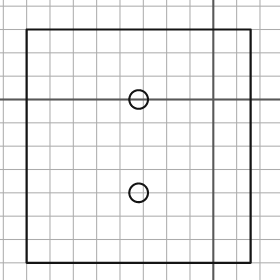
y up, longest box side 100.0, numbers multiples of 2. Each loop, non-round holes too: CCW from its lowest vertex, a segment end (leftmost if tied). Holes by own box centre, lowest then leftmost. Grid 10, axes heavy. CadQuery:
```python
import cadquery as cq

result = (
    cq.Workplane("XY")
    .moveTo(-80.0, -70.0)
    .lineTo(16.0, -70.0)
    .lineTo(16.0, 30.0)
    .lineTo(-80.0, 30.0)
    .close()
    .moveTo(-32.0, -40.0)
    .circle(4.0)
    .moveTo(-32.0, 0.0)
    .circle(4.0)
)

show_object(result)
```